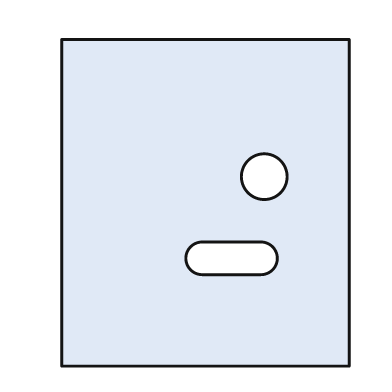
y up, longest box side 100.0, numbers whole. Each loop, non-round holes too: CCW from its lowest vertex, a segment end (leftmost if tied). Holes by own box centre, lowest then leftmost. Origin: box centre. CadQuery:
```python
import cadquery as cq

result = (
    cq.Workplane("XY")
    .moveTo(-44.0, -50.0)
    .lineTo(44.0, -50.0)
    .lineTo(44.0, 50.0)
    .lineTo(-44.0, 50.0)
    .close()
    .moveTo(-1.0, -22.0)
    .lineTo(17.0, -22.0)
    .threePointArc((22.0, -17.0), (17.0, -12.0))
    .lineTo(-1.0, -12.0)
    .threePointArc((-6.0, -17.0), (-1.0, -22.0))
    .close()
    .moveTo(18.0, 8.0)
    .circle(7.0)
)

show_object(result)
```